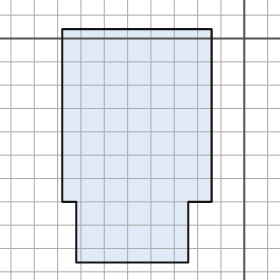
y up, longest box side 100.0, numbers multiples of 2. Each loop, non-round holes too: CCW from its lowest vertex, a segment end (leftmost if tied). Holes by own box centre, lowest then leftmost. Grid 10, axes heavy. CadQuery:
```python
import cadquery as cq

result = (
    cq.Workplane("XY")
    .moveTo(-72.0, -96.0)
    .lineTo(-24.0, -96.0)
    .lineTo(-24.0, -70.0)
    .lineTo(-14.0, -70.0)
    .lineTo(-14.0, 4.0)
    .lineTo(-78.0, 4.0)
    .lineTo(-78.0, -70.0)
    .lineTo(-72.0, -70.0)
    .close()
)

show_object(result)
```